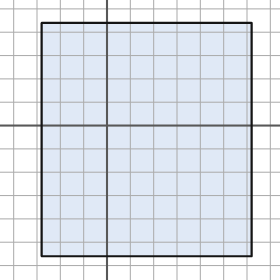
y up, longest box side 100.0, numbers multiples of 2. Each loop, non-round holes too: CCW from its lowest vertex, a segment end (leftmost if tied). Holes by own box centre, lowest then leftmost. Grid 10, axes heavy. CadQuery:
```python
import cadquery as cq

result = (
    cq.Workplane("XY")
    .moveTo(-28.0, -56.0)
    .lineTo(62.0, -56.0)
    .lineTo(62.0, 44.0)
    .lineTo(-28.0, 44.0)
    .close()
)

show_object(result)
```